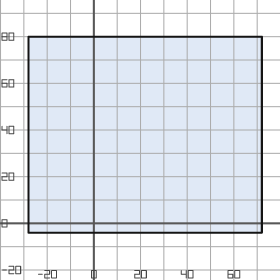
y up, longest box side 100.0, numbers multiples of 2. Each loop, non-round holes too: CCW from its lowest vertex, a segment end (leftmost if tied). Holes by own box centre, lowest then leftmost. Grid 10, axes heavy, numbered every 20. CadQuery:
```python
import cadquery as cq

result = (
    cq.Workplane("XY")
    .moveTo(-28.0, -4.0)
    .lineTo(72.0, -4.0)
    .lineTo(72.0, 80.0)
    .lineTo(-28.0, 80.0)
    .close()
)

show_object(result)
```